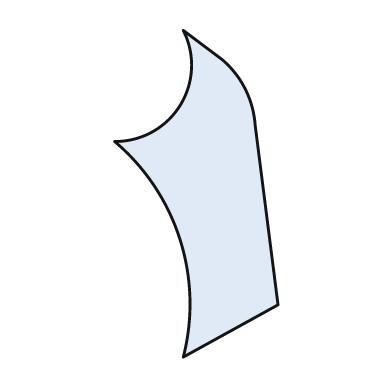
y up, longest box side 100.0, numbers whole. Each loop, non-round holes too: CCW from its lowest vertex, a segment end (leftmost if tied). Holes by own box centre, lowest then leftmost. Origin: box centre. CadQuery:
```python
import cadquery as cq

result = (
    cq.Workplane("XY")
    .moveTo(-4.0, -50.0)
    .lineTo(25.0, -34.0)
    .lineTo(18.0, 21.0)
    .threePointArc((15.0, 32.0), (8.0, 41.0))
    .lineTo(-4.0, 50.0)
    .threePointArc((-5.0, 27.0), (-25.0, 16.0))
    .threePointArc((-5.0, -14.0), (-4.0, -50.0))
    .close()
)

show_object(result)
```